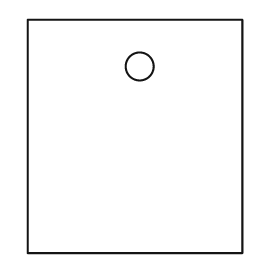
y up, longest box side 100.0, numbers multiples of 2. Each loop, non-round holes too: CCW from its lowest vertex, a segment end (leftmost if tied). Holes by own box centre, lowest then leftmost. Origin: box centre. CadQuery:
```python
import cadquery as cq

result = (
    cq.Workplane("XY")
    .moveTo(-46.0, -50.0)
    .lineTo(46.0, -50.0)
    .lineTo(46.0, 50.0)
    .lineTo(-46.0, 50.0)
    .close()
    .moveTo(2.0, 30.0)
    .circle(6.0)
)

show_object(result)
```